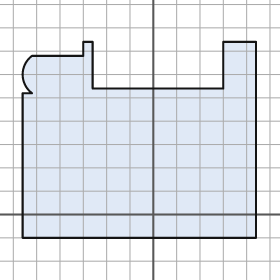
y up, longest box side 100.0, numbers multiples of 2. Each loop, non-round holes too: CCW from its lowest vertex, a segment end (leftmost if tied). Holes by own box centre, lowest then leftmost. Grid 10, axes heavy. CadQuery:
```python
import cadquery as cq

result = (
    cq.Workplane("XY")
    .moveTo(-56.0, -10.0)
    .lineTo(44.0, -10.0)
    .lineTo(44.0, 74.0)
    .lineTo(30.0, 74.0)
    .lineTo(30.0, 54.0)
    .lineTo(-26.0, 54.0)
    .lineTo(-26.0, 74.0)
    .lineTo(-30.0, 74.0)
    .lineTo(-30.0, 68.0)
    .lineTo(-52.0, 68.0)
    .threePointArc((-56.0, 60.0), (-52.0, 52.0))
    .lineTo(-56.0, 52.0)
    .close()
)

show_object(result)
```